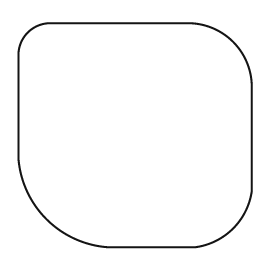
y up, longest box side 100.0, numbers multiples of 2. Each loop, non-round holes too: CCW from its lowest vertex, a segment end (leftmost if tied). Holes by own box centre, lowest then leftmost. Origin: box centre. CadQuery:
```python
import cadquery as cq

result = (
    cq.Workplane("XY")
    .moveTo(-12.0, -48.0)
    .lineTo(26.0, -48.0)
    .threePointArc((42.0, -40.0), (50.0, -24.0))
    .lineTo(50.0, 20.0)
    .threePointArc((42.0, 40.0), (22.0, 48.0))
    .lineTo(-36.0, 48.0)
    .threePointArc((-46.0, 44.0), (-50.0, 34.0))
    .lineTo(-50.0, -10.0)
    .threePointArc((-38.0, -36.0), (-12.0, -48.0))
    .close()
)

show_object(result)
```